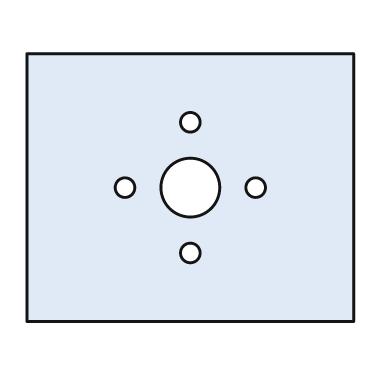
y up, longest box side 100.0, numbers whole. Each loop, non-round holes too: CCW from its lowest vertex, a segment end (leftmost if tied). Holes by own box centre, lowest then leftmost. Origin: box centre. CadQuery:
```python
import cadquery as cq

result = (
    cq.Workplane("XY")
    .moveTo(-50.0, -41.0)
    .lineTo(50.0, -41.0)
    .lineTo(50.0, 41.0)
    .lineTo(-50.0, 41.0)
    .close()
    .moveTo(0.0, -20.0)
    .circle(3.0)
    .moveTo(-20.0, 0.0)
    .circle(3.0)
    .moveTo(0.0, 0.0)
    .circle(9.0)
    .moveTo(20.0, 0.0)
    .circle(3.0)
    .moveTo(0.0, 20.0)
    .circle(3.0)
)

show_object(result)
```